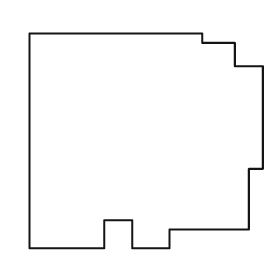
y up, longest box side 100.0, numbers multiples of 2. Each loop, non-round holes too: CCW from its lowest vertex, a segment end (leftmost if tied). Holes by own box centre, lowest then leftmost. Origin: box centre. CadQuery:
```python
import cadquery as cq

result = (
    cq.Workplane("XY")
    .moveTo(-50.0, -46.0)
    .lineTo(-18.0, -46.0)
    .lineTo(-18.0, -34.0)
    .lineTo(-6.0, -34.0)
    .lineTo(-6.0, -46.0)
    .lineTo(10.0, -46.0)
    .lineTo(10.0, -38.0)
    .lineTo(44.0, -38.0)
    .lineTo(44.0, -12.0)
    .lineTo(50.0, -12.0)
    .lineTo(50.0, 32.0)
    .lineTo(38.0, 32.0)
    .lineTo(38.0, 42.0)
    .lineTo(24.0, 42.0)
    .lineTo(24.0, 46.0)
    .lineTo(-50.0, 46.0)
    .close()
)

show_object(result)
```